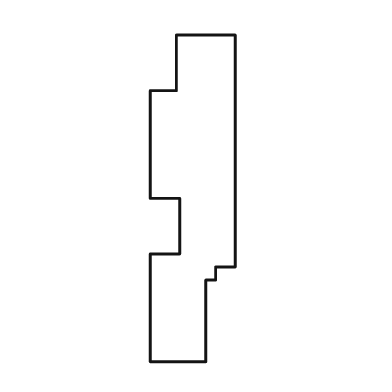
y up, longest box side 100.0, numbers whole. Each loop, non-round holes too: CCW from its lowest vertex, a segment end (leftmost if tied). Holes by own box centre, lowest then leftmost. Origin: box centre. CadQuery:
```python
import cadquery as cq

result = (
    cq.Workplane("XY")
    .moveTo(-13.0, -50.0)
    .lineTo(4.0, -50.0)
    .lineTo(4.0, -25.0)
    .lineTo(7.0, -25.0)
    .lineTo(7.0, -21.0)
    .lineTo(13.0, -21.0)
    .lineTo(13.0, 50.0)
    .lineTo(-5.0, 50.0)
    .lineTo(-5.0, 33.0)
    .lineTo(-13.0, 33.0)
    .lineTo(-13.0, 0.0)
    .lineTo(-4.0, 0.0)
    .lineTo(-4.0, -17.0)
    .lineTo(-13.0, -17.0)
    .close()
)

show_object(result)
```